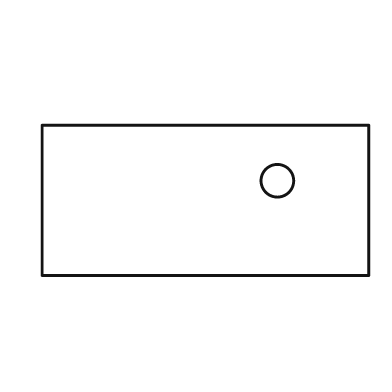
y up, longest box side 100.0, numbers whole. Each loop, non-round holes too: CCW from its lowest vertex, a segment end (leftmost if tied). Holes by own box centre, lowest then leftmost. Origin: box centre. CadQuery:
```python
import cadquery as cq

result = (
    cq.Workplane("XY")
    .moveTo(-50.0, -23.0)
    .lineTo(50.0, -23.0)
    .lineTo(50.0, 23.0)
    .lineTo(-50.0, 23.0)
    .close()
    .moveTo(22.0, 6.0)
    .circle(5.0)
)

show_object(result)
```